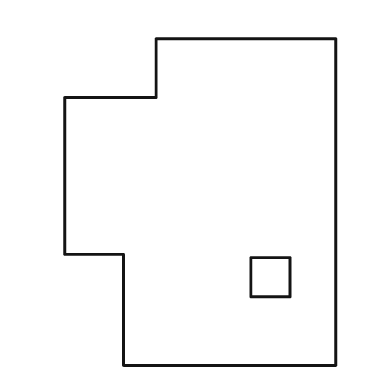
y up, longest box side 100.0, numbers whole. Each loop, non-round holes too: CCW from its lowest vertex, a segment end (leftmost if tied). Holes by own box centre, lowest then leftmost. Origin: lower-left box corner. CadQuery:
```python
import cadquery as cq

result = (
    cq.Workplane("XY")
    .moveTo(18.0, 0.0)
    .lineTo(83.0, 0.0)
    .lineTo(83.0, 100.0)
    .lineTo(28.0, 100.0)
    .lineTo(28.0, 82.0)
    .lineTo(0.0, 82.0)
    .lineTo(0.0, 34.0)
    .lineTo(18.0, 34.0)
    .close()
    .moveTo(57.0, 21.0)
    .lineTo(69.0, 21.0)
    .lineTo(69.0, 33.0)
    .lineTo(57.0, 33.0)
    .close()
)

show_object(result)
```